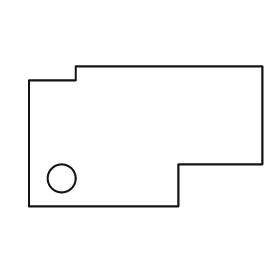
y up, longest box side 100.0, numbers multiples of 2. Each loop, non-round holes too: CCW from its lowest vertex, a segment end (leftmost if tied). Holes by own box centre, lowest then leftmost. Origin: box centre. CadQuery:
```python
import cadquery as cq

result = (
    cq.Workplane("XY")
    .moveTo(-50.0, -30.0)
    .lineTo(14.0, -30.0)
    .lineTo(14.0, -12.0)
    .lineTo(50.0, -12.0)
    .lineTo(50.0, 30.0)
    .lineTo(-30.0, 30.0)
    .lineTo(-30.0, 24.0)
    .lineTo(-50.0, 24.0)
    .close()
    .moveTo(-36.0, -18.0)
    .circle(6.0)
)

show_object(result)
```